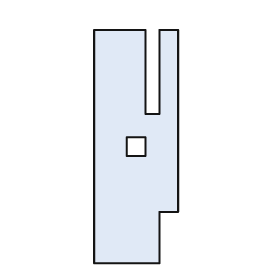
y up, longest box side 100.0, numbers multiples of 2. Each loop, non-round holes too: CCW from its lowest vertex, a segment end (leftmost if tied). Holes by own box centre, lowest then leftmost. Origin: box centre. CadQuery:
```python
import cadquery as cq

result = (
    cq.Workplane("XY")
    .moveTo(-18.0, -50.0)
    .lineTo(10.0, -50.0)
    .lineTo(10.0, -28.0)
    .lineTo(18.0, -28.0)
    .lineTo(18.0, 50.0)
    .lineTo(10.0, 50.0)
    .lineTo(10.0, 14.0)
    .lineTo(4.0, 14.0)
    .lineTo(4.0, 50.0)
    .lineTo(-18.0, 50.0)
    .close()
    .moveTo(-4.0, -4.0)
    .lineTo(4.0, -4.0)
    .lineTo(4.0, 4.0)
    .lineTo(-4.0, 4.0)
    .close()
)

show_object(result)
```